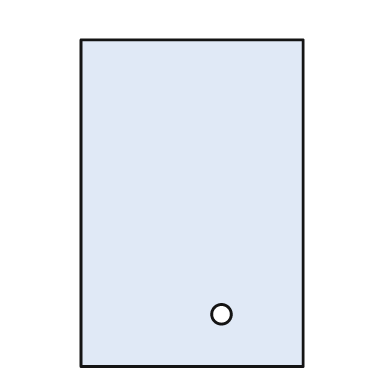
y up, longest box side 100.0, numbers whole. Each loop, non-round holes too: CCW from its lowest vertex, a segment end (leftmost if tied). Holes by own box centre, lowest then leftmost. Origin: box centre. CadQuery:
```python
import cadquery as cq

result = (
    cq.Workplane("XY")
    .moveTo(-34.0, -50.0)
    .lineTo(34.0, -50.0)
    .lineTo(34.0, 50.0)
    .lineTo(-34.0, 50.0)
    .close()
    .moveTo(9.0, -34.0)
    .circle(3.0)
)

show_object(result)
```